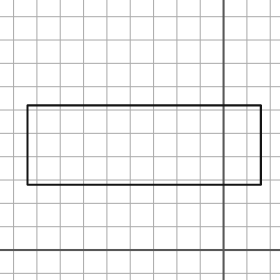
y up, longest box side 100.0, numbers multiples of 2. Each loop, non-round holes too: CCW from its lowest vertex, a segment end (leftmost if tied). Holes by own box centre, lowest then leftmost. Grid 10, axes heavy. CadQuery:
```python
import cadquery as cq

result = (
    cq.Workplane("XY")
    .moveTo(-84.0, 28.0)
    .lineTo(16.0, 28.0)
    .lineTo(16.0, 62.0)
    .lineTo(-84.0, 62.0)
    .close()
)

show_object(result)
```